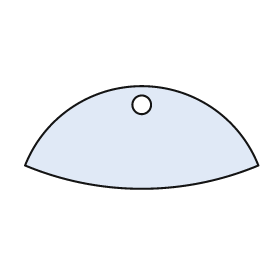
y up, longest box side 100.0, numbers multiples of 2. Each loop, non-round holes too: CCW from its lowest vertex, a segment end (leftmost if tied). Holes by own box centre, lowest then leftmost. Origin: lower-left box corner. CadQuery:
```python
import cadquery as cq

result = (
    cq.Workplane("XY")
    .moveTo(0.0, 10.0)
    .threePointArc((50.0, 0.0), (100.0, 10.0))
    .threePointArc((50.0, 44.0), (0.0, 10.0))
    .close()
    .moveTo(50.0, 36.0)
    .circle(4.0)
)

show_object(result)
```